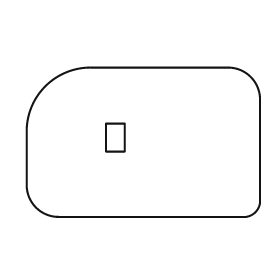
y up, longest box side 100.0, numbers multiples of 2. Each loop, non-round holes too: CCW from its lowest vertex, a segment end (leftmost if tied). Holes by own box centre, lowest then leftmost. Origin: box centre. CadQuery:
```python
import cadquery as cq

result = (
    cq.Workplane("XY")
    .moveTo(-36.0, -32.0)
    .lineTo(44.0, -32.0)
    .threePointArc((48.0, -30.0), (50.0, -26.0))
    .lineTo(50.0, 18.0)
    .threePointArc((46.0, 28.0), (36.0, 32.0))
    .lineTo(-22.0, 32.0)
    .threePointArc((-42.0, 24.0), (-50.0, 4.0))
    .lineTo(-50.0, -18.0)
    .threePointArc((-46.0, -28.0), (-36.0, -32.0))
    .close()
    .moveTo(-16.0, -4.0)
    .lineTo(-8.0, -4.0)
    .lineTo(-8.0, 8.0)
    .lineTo(-16.0, 8.0)
    .close()
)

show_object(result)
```